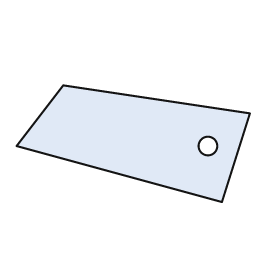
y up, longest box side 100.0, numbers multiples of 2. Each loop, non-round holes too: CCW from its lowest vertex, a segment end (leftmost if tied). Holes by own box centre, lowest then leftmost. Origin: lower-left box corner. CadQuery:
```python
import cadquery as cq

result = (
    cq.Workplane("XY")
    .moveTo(88.0, 0.0)
    .lineTo(100.0, 38.0)
    .lineTo(20.0, 50.0)
    .lineTo(0.0, 24.0)
    .close()
    .moveTo(82.0, 24.0)
    .circle(4.0)
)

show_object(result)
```